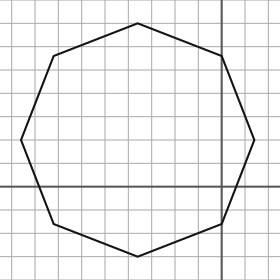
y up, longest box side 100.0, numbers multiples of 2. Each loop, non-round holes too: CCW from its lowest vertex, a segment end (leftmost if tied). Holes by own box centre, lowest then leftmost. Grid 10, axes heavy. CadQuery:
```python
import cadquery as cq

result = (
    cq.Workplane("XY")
    .moveTo(-36.0, -30.0)
    .lineTo(0.0, -16.0)
    .lineTo(14.0, 20.0)
    .lineTo(0.0, 56.0)
    .lineTo(-36.0, 70.0)
    .lineTo(-72.0, 56.0)
    .lineTo(-86.0, 20.0)
    .lineTo(-72.0, -16.0)
    .close()
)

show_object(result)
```